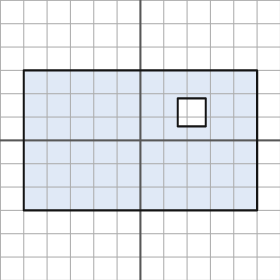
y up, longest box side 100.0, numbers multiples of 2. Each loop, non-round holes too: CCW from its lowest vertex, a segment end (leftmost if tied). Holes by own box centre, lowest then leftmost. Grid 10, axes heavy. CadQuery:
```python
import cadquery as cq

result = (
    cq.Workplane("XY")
    .moveTo(-50.0, -30.0)
    .lineTo(50.0, -30.0)
    .lineTo(50.0, 30.0)
    .lineTo(-50.0, 30.0)
    .close()
    .moveTo(16.0, 6.0)
    .lineTo(28.0, 6.0)
    .lineTo(28.0, 18.0)
    .lineTo(16.0, 18.0)
    .close()
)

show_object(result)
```